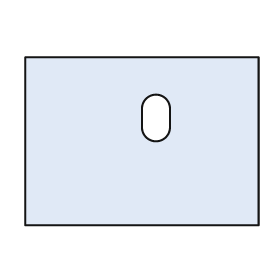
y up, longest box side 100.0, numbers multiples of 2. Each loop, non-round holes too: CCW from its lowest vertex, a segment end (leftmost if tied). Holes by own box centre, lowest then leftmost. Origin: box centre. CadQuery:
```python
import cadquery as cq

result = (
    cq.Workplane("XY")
    .moveTo(-50.0, -36.0)
    .lineTo(50.0, -36.0)
    .lineTo(50.0, 36.0)
    .lineTo(-50.0, 36.0)
    .close()
    .moveTo(0.0, 6.0)
    .threePointArc((6.0, 0.0), (12.0, 6.0))
    .lineTo(12.0, 14.0)
    .threePointArc((6.0, 20.0), (0.0, 14.0))
    .close()
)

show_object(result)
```